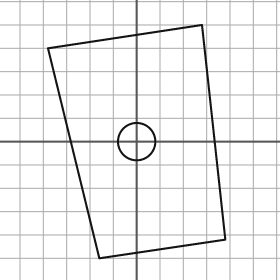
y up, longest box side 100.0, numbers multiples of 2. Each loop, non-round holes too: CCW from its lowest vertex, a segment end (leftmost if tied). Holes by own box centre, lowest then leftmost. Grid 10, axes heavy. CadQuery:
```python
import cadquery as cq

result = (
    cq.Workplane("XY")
    .moveTo(-16.0, -50.0)
    .lineTo(38.0, -42.0)
    .lineTo(28.0, 50.0)
    .lineTo(-38.0, 40.0)
    .close()
    .moveTo(0.0, 0.0)
    .circle(8.0)
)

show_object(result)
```